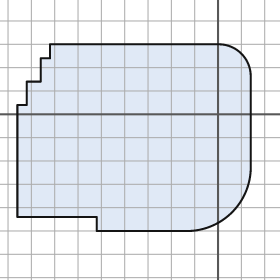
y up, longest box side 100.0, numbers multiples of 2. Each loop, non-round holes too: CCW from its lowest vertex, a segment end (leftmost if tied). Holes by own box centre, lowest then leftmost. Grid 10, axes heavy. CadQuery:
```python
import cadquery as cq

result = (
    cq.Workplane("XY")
    .moveTo(-52.0, -50.0)
    .lineTo(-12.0, -50.0)
    .threePointArc((6.0, -42.0), (14.0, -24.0))
    .lineTo(14.0, 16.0)
    .threePointArc((10.0, 26.0), (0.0, 30.0))
    .lineTo(-72.0, 30.0)
    .lineTo(-72.0, 24.0)
    .lineTo(-76.0, 24.0)
    .lineTo(-76.0, 14.0)
    .lineTo(-82.0, 14.0)
    .lineTo(-82.0, 4.0)
    .lineTo(-86.0, 4.0)
    .lineTo(-86.0, -44.0)
    .lineTo(-52.0, -44.0)
    .close()
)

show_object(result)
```